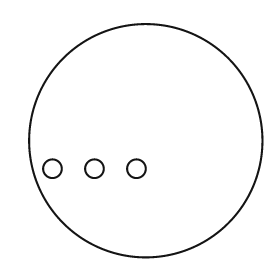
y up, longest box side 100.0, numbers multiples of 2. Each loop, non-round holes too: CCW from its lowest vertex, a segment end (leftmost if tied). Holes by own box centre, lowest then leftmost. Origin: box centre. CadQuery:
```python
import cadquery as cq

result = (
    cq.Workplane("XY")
    .moveTo(0.0, 0.0)
    .circle(50.0)
    .moveTo(-40.0, -12.0)
    .circle(4.0)
    .moveTo(-22.0, -12.0)
    .circle(4.0)
    .moveTo(-4.0, -12.0)
    .circle(4.0)
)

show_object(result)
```